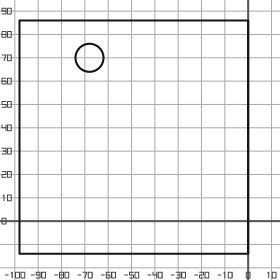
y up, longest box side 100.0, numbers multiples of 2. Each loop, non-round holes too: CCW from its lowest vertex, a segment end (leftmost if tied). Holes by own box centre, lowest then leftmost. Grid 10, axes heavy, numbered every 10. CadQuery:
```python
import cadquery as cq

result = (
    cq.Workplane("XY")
    .moveTo(-98.0, -14.0)
    .lineTo(0.0, -14.0)
    .lineTo(0.0, 86.0)
    .lineTo(-98.0, 86.0)
    .close()
    .moveTo(-68.0, 70.0)
    .circle(6.0)
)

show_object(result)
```